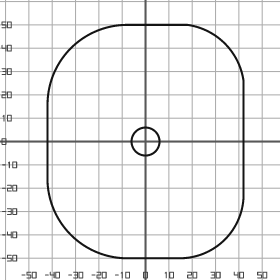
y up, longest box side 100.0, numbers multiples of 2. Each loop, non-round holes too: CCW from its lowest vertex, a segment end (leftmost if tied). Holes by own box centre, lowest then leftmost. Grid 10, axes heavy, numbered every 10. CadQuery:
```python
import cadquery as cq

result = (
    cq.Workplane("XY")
    .moveTo(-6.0, -50.0)
    .lineTo(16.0, -50.0)
    .threePointArc((34.0, -42.0), (42.0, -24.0))
    .lineTo(42.0, 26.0)
    .threePointArc((34.0, 42.0), (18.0, 50.0))
    .lineTo(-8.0, 50.0)
    .threePointArc((-32.0, 40.0), (-42.0, 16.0))
    .lineTo(-42.0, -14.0)
    .threePointArc((-32.0, -40.0), (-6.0, -50.0))
    .close()
    .moveTo(0.0, 0.0)
    .circle(6.0)
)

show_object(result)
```